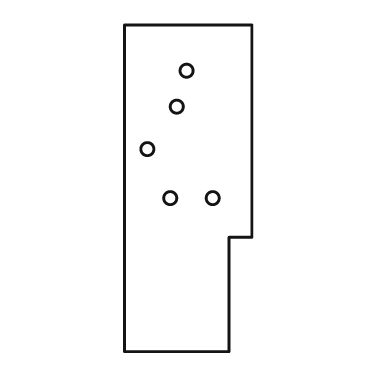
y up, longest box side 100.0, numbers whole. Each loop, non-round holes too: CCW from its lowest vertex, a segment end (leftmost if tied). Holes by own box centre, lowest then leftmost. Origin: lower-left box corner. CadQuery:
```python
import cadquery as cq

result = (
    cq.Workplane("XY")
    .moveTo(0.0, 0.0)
    .lineTo(32.0, 0.0)
    .lineTo(32.0, 35.0)
    .lineTo(39.0, 35.0)
    .lineTo(39.0, 100.0)
    .lineTo(0.0, 100.0)
    .close()
    .moveTo(14.0, 47.0)
    .circle(2.0)
    .moveTo(27.0, 47.0)
    .circle(2.0)
    .moveTo(7.0, 62.0)
    .circle(2.0)
    .moveTo(16.0, 75.0)
    .circle(2.0)
    .moveTo(19.0, 86.0)
    .circle(2.0)
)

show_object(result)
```